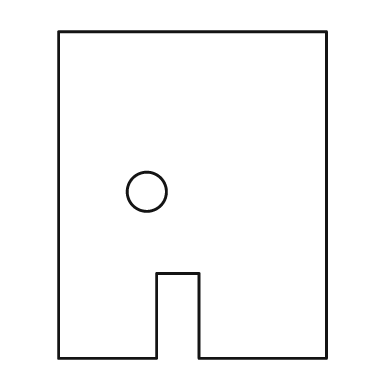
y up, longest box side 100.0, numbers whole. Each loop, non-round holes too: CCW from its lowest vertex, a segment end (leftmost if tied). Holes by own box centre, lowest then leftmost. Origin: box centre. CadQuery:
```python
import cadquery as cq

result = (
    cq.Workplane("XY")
    .moveTo(-41.0, -50.0)
    .lineTo(-11.0, -50.0)
    .lineTo(-11.0, -24.0)
    .lineTo(2.0, -24.0)
    .lineTo(2.0, -50.0)
    .lineTo(41.0, -50.0)
    .lineTo(41.0, 50.0)
    .lineTo(-41.0, 50.0)
    .close()
    .moveTo(-14.0, 1.0)
    .circle(6.0)
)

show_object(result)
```